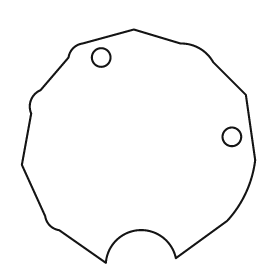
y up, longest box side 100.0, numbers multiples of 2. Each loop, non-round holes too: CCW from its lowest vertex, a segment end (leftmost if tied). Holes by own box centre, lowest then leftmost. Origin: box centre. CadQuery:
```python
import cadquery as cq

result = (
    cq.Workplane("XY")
    .moveTo(-14.0, -50.0)
    .threePointArc((0.0, -36.0), (16.0, -48.0))
    .lineTo(38.0, -32.0)
    .threePointArc((46.0, -20.0), (50.0, -6.0))
    .lineTo(46.0, 22.0)
    .lineTo(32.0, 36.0)
    .threePointArc((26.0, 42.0), (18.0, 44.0))
    .lineTo(-2.0, 50.0)
    .lineTo(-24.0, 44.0)
    .threePointArc((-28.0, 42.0), (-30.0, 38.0))
    .lineTo(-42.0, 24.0)
    .threePointArc((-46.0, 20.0), (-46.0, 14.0))
    .lineTo(-50.0, -8.0)
    .lineTo(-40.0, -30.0)
    .threePointArc((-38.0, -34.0), (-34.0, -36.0))
    .close()
    .moveTo(40.0, 4.0)
    .circle(4.0)
    .moveTo(-16.0, 38.0)
    .circle(4.0)
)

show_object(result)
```